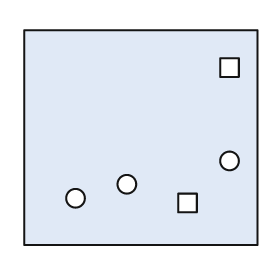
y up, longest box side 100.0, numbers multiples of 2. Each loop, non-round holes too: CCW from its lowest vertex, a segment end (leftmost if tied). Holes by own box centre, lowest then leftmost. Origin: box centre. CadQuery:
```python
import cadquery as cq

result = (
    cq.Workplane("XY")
    .moveTo(-50.0, -46.0)
    .lineTo(50.0, -46.0)
    .lineTo(50.0, 46.0)
    .lineTo(-50.0, 46.0)
    .close()
    .moveTo(16.0, -32.0)
    .lineTo(24.0, -32.0)
    .lineTo(24.0, -24.0)
    .lineTo(16.0, -24.0)
    .close()
    .moveTo(-28.0, -26.0)
    .circle(4.0)
    .moveTo(-6.0, -20.0)
    .circle(4.0)
    .moveTo(38.0, -10.0)
    .circle(4.0)
    .moveTo(34.0, 26.0)
    .lineTo(42.0, 26.0)
    .lineTo(42.0, 34.0)
    .lineTo(34.0, 34.0)
    .close()
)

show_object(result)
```